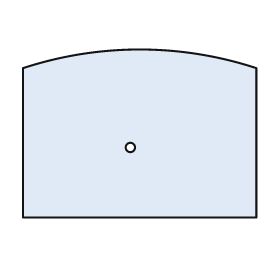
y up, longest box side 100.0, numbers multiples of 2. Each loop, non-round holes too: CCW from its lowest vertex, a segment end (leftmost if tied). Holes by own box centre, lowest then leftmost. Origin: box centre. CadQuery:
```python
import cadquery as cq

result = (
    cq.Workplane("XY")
    .moveTo(-50.0, -36.0)
    .lineTo(50.0, -36.0)
    .lineTo(50.0, 28.0)
    .threePointArc((0.0, 36.0), (-50.0, 28.0))
    .close()
    .moveTo(-4.0, -6.0)
    .circle(2.0)
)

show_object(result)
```